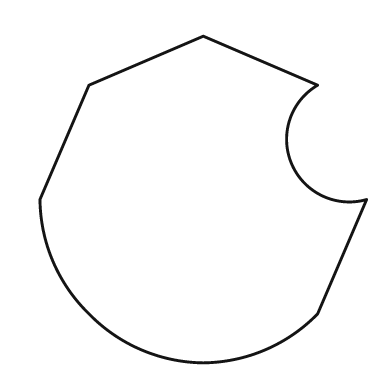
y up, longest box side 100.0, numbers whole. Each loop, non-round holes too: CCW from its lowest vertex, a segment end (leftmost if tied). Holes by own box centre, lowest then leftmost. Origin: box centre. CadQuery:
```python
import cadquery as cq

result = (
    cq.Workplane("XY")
    .moveTo(0.0, -50.0)
    .threePointArc((19.0, -46.0), (35.0, -35.0))
    .lineTo(50.0, 0.0)
    .threePointArc((27.0, 11.0), (35.0, 35.0))
    .lineTo(0.0, 50.0)
    .lineTo(-35.0, 35.0)
    .lineTo(-50.0, 0.0)
    .threePointArc((-46.0, -19.0), (-35.0, -35.0))
    .threePointArc((-19.0, -46.0), (0.0, -50.0))
    .close()
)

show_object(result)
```